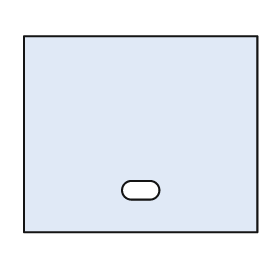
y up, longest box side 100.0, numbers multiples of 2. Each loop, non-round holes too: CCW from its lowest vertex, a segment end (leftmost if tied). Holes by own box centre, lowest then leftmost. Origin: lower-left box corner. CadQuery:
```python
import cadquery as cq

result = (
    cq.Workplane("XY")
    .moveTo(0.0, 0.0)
    .lineTo(100.0, 0.0)
    .lineTo(100.0, 84.0)
    .lineTo(0.0, 84.0)
    .close()
    .moveTo(46.0, 14.0)
    .lineTo(54.0, 14.0)
    .threePointArc((58.0, 18.0), (54.0, 22.0))
    .lineTo(46.0, 22.0)
    .threePointArc((42.0, 18.0), (46.0, 14.0))
    .close()
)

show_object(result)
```